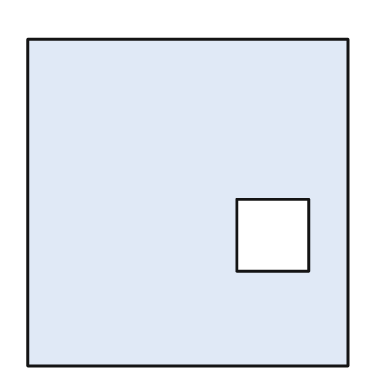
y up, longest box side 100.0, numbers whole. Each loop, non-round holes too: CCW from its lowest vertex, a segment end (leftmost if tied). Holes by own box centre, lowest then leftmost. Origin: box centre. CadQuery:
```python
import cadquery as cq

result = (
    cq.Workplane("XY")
    .moveTo(-49.0, -50.0)
    .lineTo(49.0, -50.0)
    .lineTo(49.0, 50.0)
    .lineTo(-49.0, 50.0)
    .close()
    .moveTo(15.0, -21.0)
    .lineTo(37.0, -21.0)
    .lineTo(37.0, 1.0)
    .lineTo(15.0, 1.0)
    .close()
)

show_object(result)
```